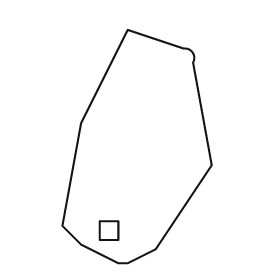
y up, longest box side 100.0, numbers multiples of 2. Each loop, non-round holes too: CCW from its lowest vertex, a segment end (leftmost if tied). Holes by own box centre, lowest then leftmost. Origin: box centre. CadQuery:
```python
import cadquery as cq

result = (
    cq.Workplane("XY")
    .moveTo(-8.0, -50.0)
    .lineTo(-4.0, -50.0)
    .lineTo(8.0, -44.0)
    .lineTo(32.0, -8.0)
    .lineTo(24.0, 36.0)
    .threePointArc((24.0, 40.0), (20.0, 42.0))
    .lineTo(-4.0, 50.0)
    .lineTo(-24.0, 10.0)
    .lineTo(-32.0, -34.0)
    .lineTo(-24.0, -42.0)
    .close()
    .moveTo(-16.0, -40.0)
    .lineTo(-8.0, -40.0)
    .lineTo(-8.0, -32.0)
    .lineTo(-16.0, -32.0)
    .close()
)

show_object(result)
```